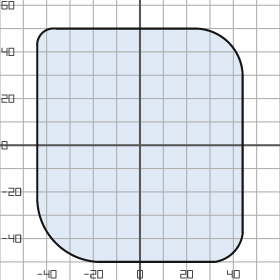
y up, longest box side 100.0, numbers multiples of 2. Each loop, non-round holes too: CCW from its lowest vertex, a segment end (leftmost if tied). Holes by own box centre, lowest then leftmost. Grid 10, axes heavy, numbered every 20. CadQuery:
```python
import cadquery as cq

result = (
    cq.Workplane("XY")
    .moveTo(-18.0, -50.0)
    .lineTo(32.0, -50.0)
    .threePointArc((40.0, -46.0), (44.0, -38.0))
    .lineTo(44.0, 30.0)
    .threePointArc((38.0, 44.0), (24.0, 50.0))
    .lineTo(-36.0, 50.0)
    .threePointArc((-42.0, 48.0), (-44.0, 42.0))
    .lineTo(-44.0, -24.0)
    .threePointArc((-36.0, -42.0), (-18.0, -50.0))
    .close()
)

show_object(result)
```